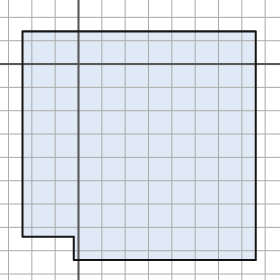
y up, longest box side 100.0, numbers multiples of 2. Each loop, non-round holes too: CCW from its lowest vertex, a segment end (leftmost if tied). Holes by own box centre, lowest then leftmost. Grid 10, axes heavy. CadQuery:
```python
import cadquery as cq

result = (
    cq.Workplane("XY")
    .moveTo(-2.0, -84.0)
    .lineTo(76.0, -84.0)
    .lineTo(76.0, 14.0)
    .lineTo(-24.0, 14.0)
    .lineTo(-24.0, -74.0)
    .lineTo(-2.0, -74.0)
    .close()
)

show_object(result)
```